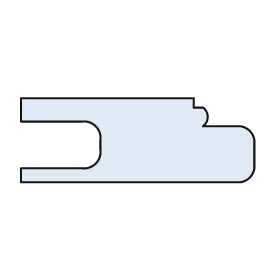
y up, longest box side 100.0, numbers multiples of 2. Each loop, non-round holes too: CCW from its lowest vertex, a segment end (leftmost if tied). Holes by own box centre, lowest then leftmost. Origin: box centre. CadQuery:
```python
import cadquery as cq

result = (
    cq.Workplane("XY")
    .moveTo(-50.0, -18.0)
    .lineTo(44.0, -18.0)
    .threePointArc((48.0, -16.0), (50.0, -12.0))
    .lineTo(50.0, 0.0)
    .threePointArc((48.0, 4.0), (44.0, 6.0))
    .lineTo(28.0, 6.0)
    .threePointArc((30.0, 10.0), (28.0, 14.0))
    .lineTo(24.0, 14.0)
    .lineTo(24.0, 18.0)
    .lineTo(-50.0, 18.0)
    .lineTo(-50.0, 8.0)
    .lineTo(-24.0, 8.0)
    .threePointArc((-18.0, 6.0), (-16.0, 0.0))
    .lineTo(-16.0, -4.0)
    .threePointArc((-18.0, -10.0), (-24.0, -12.0))
    .lineTo(-50.0, -12.0)
    .close()
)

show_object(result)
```